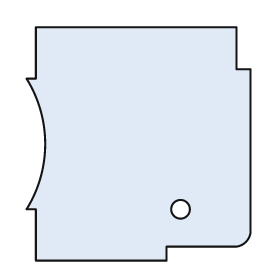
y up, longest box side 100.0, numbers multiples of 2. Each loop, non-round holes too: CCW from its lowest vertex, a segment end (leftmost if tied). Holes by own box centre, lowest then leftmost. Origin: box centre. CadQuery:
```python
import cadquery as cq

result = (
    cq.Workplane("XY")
    .moveTo(-44.0, -50.0)
    .lineTo(12.0, -50.0)
    .lineTo(12.0, -44.0)
    .lineTo(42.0, -44.0)
    .threePointArc((46.0, -42.0), (48.0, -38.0))
    .lineTo(48.0, 32.0)
    .lineTo(42.0, 32.0)
    .lineTo(42.0, 50.0)
    .lineTo(-44.0, 50.0)
    .lineTo(-44.0, 28.0)
    .lineTo(-48.0, 28.0)
    .threePointArc((-40.0, 0.0), (-48.0, -28.0))
    .lineTo(-44.0, -28.0)
    .close()
    .moveTo(18.0, -28.0)
    .circle(4.0)
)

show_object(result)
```